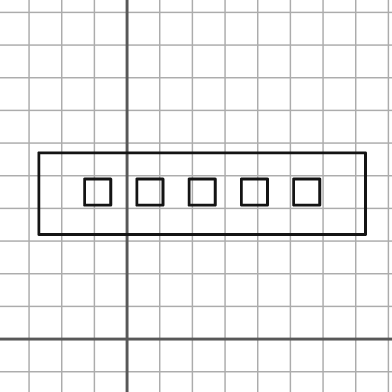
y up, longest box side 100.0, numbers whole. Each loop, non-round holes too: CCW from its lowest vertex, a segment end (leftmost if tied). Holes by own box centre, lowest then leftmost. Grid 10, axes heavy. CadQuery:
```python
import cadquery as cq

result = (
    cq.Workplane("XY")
    .moveTo(-27.0, 32.0)
    .lineTo(73.0, 32.0)
    .lineTo(73.0, 57.0)
    .lineTo(-27.0, 57.0)
    .close()
    .moveTo(-13.0, 41.0)
    .lineTo(-5.0, 41.0)
    .lineTo(-5.0, 49.0)
    .lineTo(-13.0, 49.0)
    .close()
    .moveTo(3.0, 41.0)
    .lineTo(11.0, 41.0)
    .lineTo(11.0, 49.0)
    .lineTo(3.0, 49.0)
    .close()
    .moveTo(19.0, 41.0)
    .lineTo(27.0, 41.0)
    .lineTo(27.0, 49.0)
    .lineTo(19.0, 49.0)
    .close()
    .moveTo(35.0, 41.0)
    .lineTo(43.0, 41.0)
    .lineTo(43.0, 49.0)
    .lineTo(35.0, 49.0)
    .close()
    .moveTo(51.0, 41.0)
    .lineTo(59.0, 41.0)
    .lineTo(59.0, 49.0)
    .lineTo(51.0, 49.0)
    .close()
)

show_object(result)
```